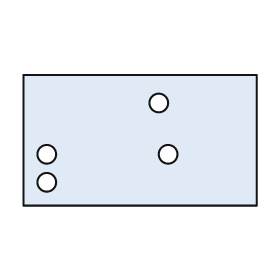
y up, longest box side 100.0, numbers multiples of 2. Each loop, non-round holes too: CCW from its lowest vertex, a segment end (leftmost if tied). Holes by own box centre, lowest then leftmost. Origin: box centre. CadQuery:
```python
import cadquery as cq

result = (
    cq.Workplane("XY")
    .moveTo(-50.0, -28.0)
    .lineTo(50.0, -28.0)
    .lineTo(50.0, 28.0)
    .lineTo(-50.0, 28.0)
    .close()
    .moveTo(-40.0, -18.0)
    .circle(4.0)
    .moveTo(-40.0, -6.0)
    .circle(4.0)
    .moveTo(12.0, -6.0)
    .circle(4.0)
    .moveTo(8.0, 16.0)
    .circle(4.0)
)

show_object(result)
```